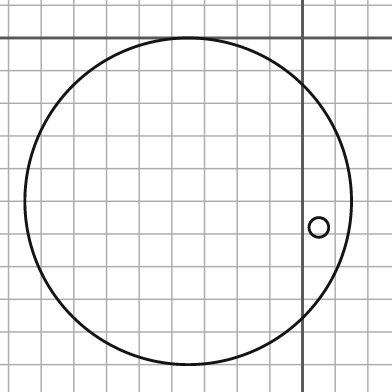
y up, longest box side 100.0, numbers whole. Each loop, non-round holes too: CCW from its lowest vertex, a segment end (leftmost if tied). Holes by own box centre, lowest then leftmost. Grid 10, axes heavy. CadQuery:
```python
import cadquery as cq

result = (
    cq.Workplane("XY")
    .moveTo(-35.0, -50.0)
    .circle(50.0)
    .moveTo(5.0, -58.0)
    .circle(3.0)
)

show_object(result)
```